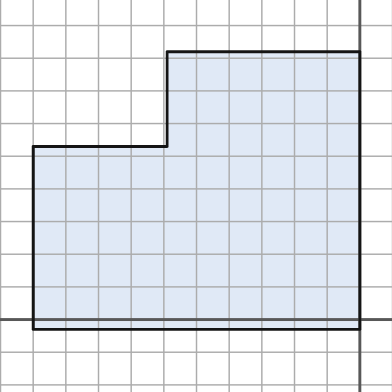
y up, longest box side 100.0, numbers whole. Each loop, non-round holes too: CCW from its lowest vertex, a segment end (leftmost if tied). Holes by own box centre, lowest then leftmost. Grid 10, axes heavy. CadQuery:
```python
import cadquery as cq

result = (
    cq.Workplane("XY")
    .moveTo(-100.0, -3.0)
    .lineTo(0.0, -3.0)
    .lineTo(0.0, 82.0)
    .lineTo(-59.0, 82.0)
    .lineTo(-59.0, 53.0)
    .lineTo(-100.0, 53.0)
    .close()
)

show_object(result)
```